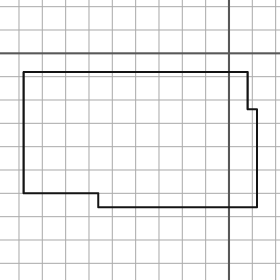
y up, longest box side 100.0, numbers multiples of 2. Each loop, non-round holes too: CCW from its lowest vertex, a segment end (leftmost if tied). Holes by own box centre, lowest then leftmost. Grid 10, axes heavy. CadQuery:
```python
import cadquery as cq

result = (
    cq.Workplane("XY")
    .moveTo(-56.0, -66.0)
    .lineTo(12.0, -66.0)
    .lineTo(12.0, -24.0)
    .lineTo(8.0, -24.0)
    .lineTo(8.0, -8.0)
    .lineTo(-88.0, -8.0)
    .lineTo(-88.0, -60.0)
    .lineTo(-56.0, -60.0)
    .close()
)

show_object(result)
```